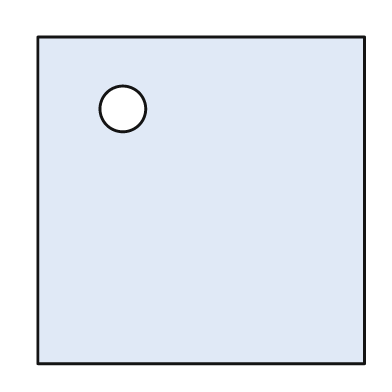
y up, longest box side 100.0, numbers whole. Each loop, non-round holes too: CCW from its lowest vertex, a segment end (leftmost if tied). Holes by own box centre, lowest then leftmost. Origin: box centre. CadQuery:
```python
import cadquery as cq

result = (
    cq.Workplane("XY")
    .moveTo(-50.0, -50.0)
    .lineTo(50.0, -50.0)
    .lineTo(50.0, 50.0)
    .lineTo(-50.0, 50.0)
    .close()
    .moveTo(-24.0, 28.0)
    .circle(7.0)
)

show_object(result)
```